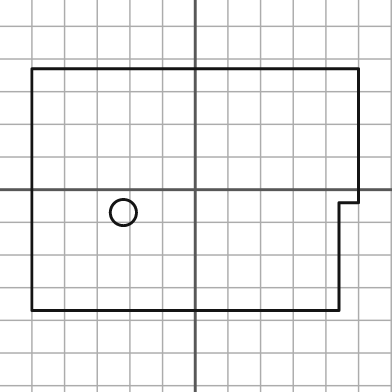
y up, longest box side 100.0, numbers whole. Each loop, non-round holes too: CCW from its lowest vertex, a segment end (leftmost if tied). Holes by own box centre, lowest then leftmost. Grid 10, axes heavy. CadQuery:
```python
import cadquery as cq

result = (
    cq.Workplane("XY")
    .moveTo(-50.0, -37.0)
    .lineTo(44.0, -37.0)
    .lineTo(44.0, -4.0)
    .lineTo(50.0, -4.0)
    .lineTo(50.0, 37.0)
    .lineTo(-50.0, 37.0)
    .close()
    .moveTo(-22.0, -7.0)
    .circle(4.0)
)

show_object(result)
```